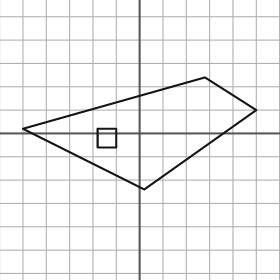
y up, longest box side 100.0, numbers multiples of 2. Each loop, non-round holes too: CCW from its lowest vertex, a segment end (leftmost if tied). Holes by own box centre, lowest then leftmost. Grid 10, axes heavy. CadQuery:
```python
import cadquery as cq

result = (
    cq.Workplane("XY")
    .moveTo(2.0, -24.0)
    .lineTo(50.0, 10.0)
    .lineTo(28.0, 24.0)
    .lineTo(-50.0, 2.0)
    .close()
    .moveTo(-18.0, -6.0)
    .lineTo(-10.0, -6.0)
    .lineTo(-10.0, 2.0)
    .lineTo(-18.0, 2.0)
    .close()
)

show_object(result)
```